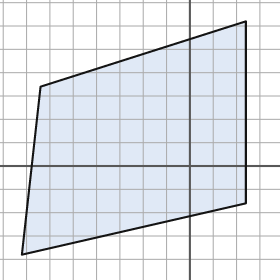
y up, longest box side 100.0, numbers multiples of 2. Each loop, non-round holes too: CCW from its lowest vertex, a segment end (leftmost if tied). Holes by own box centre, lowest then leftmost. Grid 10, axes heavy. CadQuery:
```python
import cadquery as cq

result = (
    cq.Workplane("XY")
    .moveTo(-72.0, -38.0)
    .lineTo(24.0, -16.0)
    .lineTo(24.0, 62.0)
    .lineTo(-64.0, 34.0)
    .close()
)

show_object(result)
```